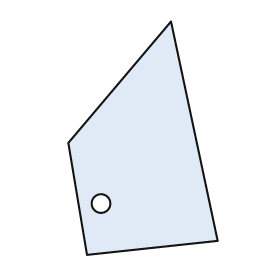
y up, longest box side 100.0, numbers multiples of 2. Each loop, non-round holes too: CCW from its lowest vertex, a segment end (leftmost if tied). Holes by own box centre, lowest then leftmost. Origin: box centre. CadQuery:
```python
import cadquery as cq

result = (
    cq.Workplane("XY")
    .moveTo(-24.0, -50.0)
    .lineTo(32.0, -44.0)
    .lineTo(12.0, 50.0)
    .lineTo(-32.0, -2.0)
    .close()
    .moveTo(-18.0, -28.0)
    .circle(4.0)
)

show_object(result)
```